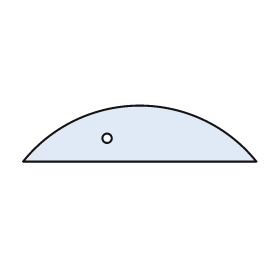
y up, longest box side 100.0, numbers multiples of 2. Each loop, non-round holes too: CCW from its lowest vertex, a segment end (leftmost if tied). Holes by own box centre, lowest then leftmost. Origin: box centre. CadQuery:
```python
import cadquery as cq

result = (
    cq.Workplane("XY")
    .moveTo(-50.0, -12.0)
    .lineTo(50.0, -12.0)
    .threePointArc((0.0, 12.0), (-50.0, -12.0))
    .close()
    .moveTo(-14.0, -2.0)
    .circle(2.0)
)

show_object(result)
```